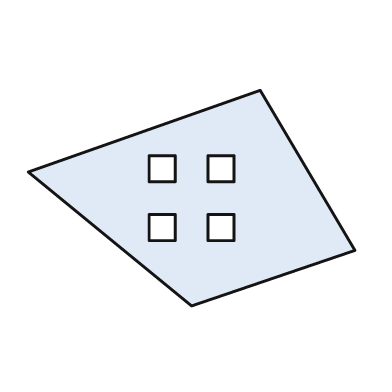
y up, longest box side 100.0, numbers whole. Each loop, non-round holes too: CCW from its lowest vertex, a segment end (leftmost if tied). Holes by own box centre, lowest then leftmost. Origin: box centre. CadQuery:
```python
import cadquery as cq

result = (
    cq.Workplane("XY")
    .moveTo(0.0, -33.0)
    .lineTo(50.0, -16.0)
    .lineTo(21.0, 33.0)
    .lineTo(-50.0, 8.0)
    .close()
    .moveTo(-13.0, -13.0)
    .lineTo(-5.0, -13.0)
    .lineTo(-5.0, -5.0)
    .lineTo(-13.0, -5.0)
    .close()
    .moveTo(5.0, -13.0)
    .lineTo(13.0, -13.0)
    .lineTo(13.0, -5.0)
    .lineTo(5.0, -5.0)
    .close()
    .moveTo(-13.0, 5.0)
    .lineTo(-5.0, 5.0)
    .lineTo(-5.0, 13.0)
    .lineTo(-13.0, 13.0)
    .close()
    .moveTo(5.0, 5.0)
    .lineTo(13.0, 5.0)
    .lineTo(13.0, 13.0)
    .lineTo(5.0, 13.0)
    .close()
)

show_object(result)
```